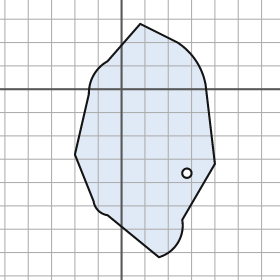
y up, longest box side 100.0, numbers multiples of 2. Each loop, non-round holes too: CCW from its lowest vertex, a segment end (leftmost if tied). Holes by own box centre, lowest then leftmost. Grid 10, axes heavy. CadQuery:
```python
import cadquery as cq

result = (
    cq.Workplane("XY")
    .moveTo(16.0, -72.0)
    .threePointArc((24.0, -66.0), (26.0, -56.0))
    .lineTo(40.0, -32.0)
    .lineTo(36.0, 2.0)
    .threePointArc((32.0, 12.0), (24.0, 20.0))
    .lineTo(8.0, 28.0)
    .lineTo(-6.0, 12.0)
    .threePointArc((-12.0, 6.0), (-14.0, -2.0))
    .lineTo(-20.0, -28.0)
    .lineTo(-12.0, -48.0)
    .threePointArc((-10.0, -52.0), (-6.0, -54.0))
    .close()
    .moveTo(28.0, -36.0)
    .circle(2.0)
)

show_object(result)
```